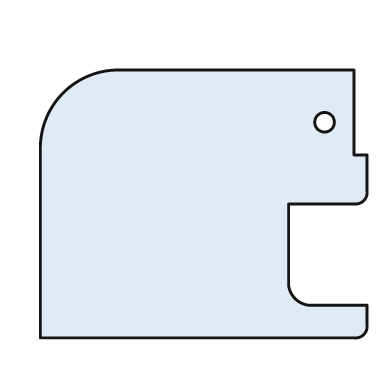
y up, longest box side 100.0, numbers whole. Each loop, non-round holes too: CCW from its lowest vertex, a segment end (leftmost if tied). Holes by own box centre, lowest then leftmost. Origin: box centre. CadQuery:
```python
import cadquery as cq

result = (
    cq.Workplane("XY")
    .moveTo(-50.0, -41.0)
    .lineTo(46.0, -41.0)
    .threePointArc((49.0, -40.0), (50.0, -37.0))
    .lineTo(50.0, -31.0)
    .lineTo(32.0, -31.0)
    .threePointArc((28.0, -29.0), (26.0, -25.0))
    .lineTo(26.0, 0.0)
    .lineTo(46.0, 0.0)
    .threePointArc((49.0, 1.0), (50.0, 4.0))
    .lineTo(50.0, 15.0)
    .lineTo(46.0, 15.0)
    .lineTo(46.0, 41.0)
    .lineTo(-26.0, 41.0)
    .threePointArc((-43.0, 34.0), (-50.0, 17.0))
    .close()
    .moveTo(37.0, 25.0)
    .circle(3.0)
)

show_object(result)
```